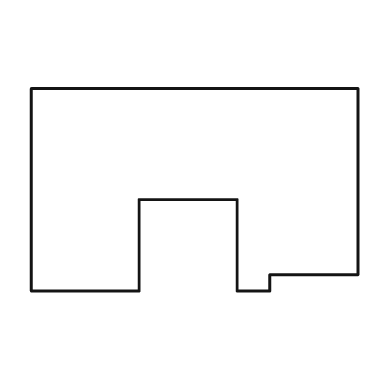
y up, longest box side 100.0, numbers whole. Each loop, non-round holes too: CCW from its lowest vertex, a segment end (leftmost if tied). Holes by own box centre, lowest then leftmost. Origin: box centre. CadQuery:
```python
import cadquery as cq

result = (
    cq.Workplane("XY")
    .moveTo(-50.0, -31.0)
    .lineTo(-17.0, -31.0)
    .lineTo(-17.0, -3.0)
    .lineTo(13.0, -3.0)
    .lineTo(13.0, -31.0)
    .lineTo(23.0, -31.0)
    .lineTo(23.0, -26.0)
    .lineTo(50.0, -26.0)
    .lineTo(50.0, 31.0)
    .lineTo(-50.0, 31.0)
    .close()
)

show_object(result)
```